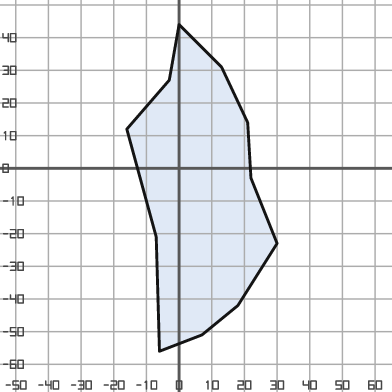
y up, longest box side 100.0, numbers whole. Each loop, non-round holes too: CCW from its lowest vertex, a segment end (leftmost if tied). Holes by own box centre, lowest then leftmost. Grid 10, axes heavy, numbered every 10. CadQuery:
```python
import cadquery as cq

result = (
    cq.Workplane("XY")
    .moveTo(-6.0, -56.0)
    .lineTo(7.0, -51.0)
    .lineTo(18.0, -42.0)
    .lineTo(30.0, -23.0)
    .lineTo(22.0, -3.0)
    .lineTo(21.0, 14.0)
    .lineTo(13.0, 31.0)
    .lineTo(0.0, 44.0)
    .lineTo(-3.0, 27.0)
    .lineTo(-16.0, 12.0)
    .lineTo(-7.0, -21.0)
    .close()
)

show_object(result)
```